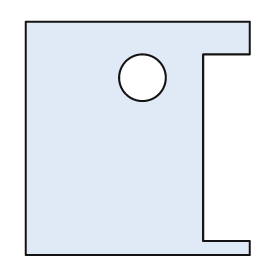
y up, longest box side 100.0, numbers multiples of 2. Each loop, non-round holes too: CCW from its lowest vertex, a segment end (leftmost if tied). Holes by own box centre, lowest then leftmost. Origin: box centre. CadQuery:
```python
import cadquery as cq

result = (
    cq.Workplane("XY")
    .moveTo(-48.0, -50.0)
    .lineTo(48.0, -50.0)
    .lineTo(48.0, -44.0)
    .lineTo(28.0, -44.0)
    .lineTo(28.0, 36.0)
    .lineTo(48.0, 36.0)
    .lineTo(48.0, 50.0)
    .lineTo(-48.0, 50.0)
    .close()
    .moveTo(2.0, 26.0)
    .circle(10.0)
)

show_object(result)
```